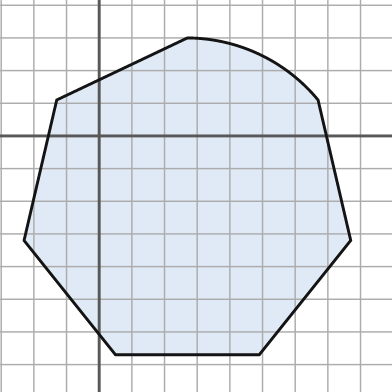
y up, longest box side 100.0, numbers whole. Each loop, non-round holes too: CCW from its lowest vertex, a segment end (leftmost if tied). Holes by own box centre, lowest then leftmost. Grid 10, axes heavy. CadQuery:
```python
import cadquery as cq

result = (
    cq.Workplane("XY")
    .moveTo(5.0, -67.0)
    .lineTo(49.0, -67.0)
    .lineTo(77.0, -32.0)
    .lineTo(67.0, 11.0)
    .threePointArc((49.0, 25.0), (27.0, 30.0))
    .lineTo(-13.0, 11.0)
    .lineTo(-23.0, -32.0)
    .close()
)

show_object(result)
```